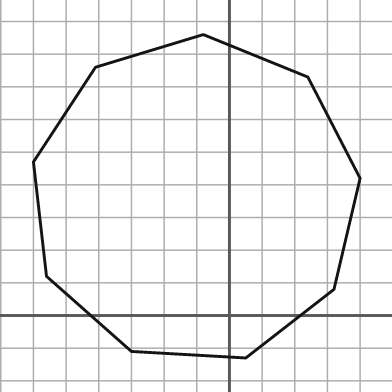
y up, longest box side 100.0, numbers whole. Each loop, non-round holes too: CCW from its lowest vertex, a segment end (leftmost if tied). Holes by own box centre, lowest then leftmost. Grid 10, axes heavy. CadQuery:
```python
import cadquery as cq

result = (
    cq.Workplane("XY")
    .moveTo(5.0, -13.0)
    .lineTo(32.0, 8.0)
    .lineTo(40.0, 42.0)
    .lineTo(24.0, 73.0)
    .lineTo(-8.0, 86.0)
    .lineTo(-41.0, 76.0)
    .lineTo(-60.0, 47.0)
    .lineTo(-56.0, 12.0)
    .lineTo(-30.0, -11.0)
    .close()
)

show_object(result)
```